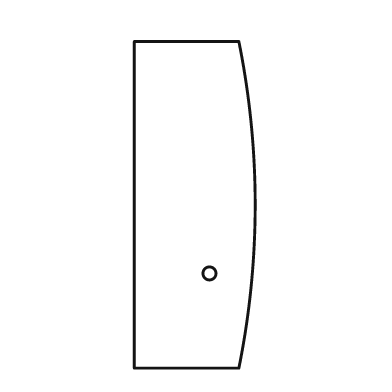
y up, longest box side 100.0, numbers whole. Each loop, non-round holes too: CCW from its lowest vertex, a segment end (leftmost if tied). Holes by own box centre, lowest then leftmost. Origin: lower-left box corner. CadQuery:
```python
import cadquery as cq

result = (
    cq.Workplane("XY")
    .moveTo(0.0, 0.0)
    .lineTo(32.0, 0.0)
    .threePointArc((37.0, 50.0), (32.0, 100.0))
    .lineTo(0.0, 100.0)
    .close()
    .moveTo(23.0, 29.0)
    .circle(2.0)
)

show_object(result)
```